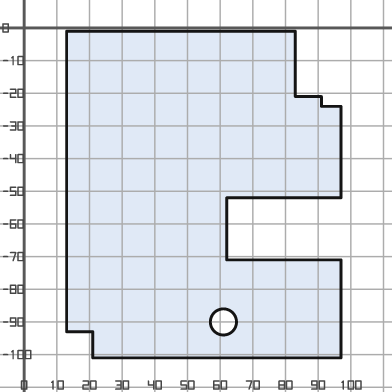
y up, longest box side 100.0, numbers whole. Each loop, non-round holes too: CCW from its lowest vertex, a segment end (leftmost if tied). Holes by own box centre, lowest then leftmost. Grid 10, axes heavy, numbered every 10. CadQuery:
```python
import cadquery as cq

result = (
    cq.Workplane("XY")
    .moveTo(21.0, -101.0)
    .lineTo(97.0, -101.0)
    .lineTo(97.0, -71.0)
    .lineTo(62.0, -71.0)
    .lineTo(62.0, -52.0)
    .lineTo(97.0, -52.0)
    .lineTo(97.0, -24.0)
    .lineTo(91.0, -24.0)
    .lineTo(91.0, -21.0)
    .lineTo(83.0, -21.0)
    .lineTo(83.0, -1.0)
    .lineTo(13.0, -1.0)
    .lineTo(13.0, -93.0)
    .lineTo(21.0, -93.0)
    .close()
    .moveTo(61.0, -90.0)
    .circle(4.0)
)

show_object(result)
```